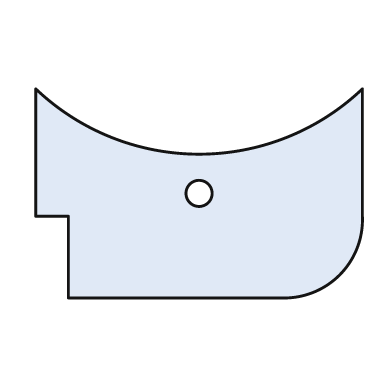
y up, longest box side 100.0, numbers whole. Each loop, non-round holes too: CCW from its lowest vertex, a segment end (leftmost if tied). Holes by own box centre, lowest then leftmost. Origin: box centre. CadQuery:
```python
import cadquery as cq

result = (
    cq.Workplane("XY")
    .moveTo(-40.0, -32.0)
    .lineTo(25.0, -32.0)
    .threePointArc((43.0, -25.0), (50.0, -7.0))
    .lineTo(50.0, 32.0)
    .threePointArc((0.0, 12.0), (-50.0, 32.0))
    .lineTo(-50.0, -7.0)
    .lineTo(-40.0, -7.0)
    .close()
    .moveTo(0.0, 0.0)
    .circle(4.0)
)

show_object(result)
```